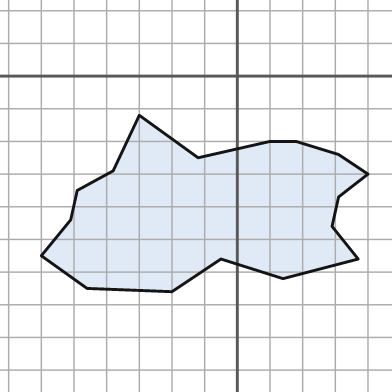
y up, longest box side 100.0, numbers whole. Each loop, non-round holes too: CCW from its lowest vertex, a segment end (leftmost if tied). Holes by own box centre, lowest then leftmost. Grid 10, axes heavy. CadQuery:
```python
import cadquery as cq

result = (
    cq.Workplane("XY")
    .moveTo(-20.0, -66.0)
    .lineTo(-5.0, -56.0)
    .lineTo(14.0, -62.0)
    .lineTo(37.0, -56.0)
    .lineTo(29.0, -46.0)
    .lineTo(31.0, -37.0)
    .lineTo(40.0, -30.0)
    .lineTo(31.0, -24.0)
    .lineTo(18.0, -20.0)
    .lineTo(10.0, -20.0)
    .lineTo(-12.0, -25.0)
    .lineTo(-30.0, -12.0)
    .lineTo(-38.0, -29.0)
    .lineTo(-49.0, -35.0)
    .lineTo(-51.0, -44.0)
    .lineTo(-60.0, -55.0)
    .lineTo(-46.0, -65.0)
    .close()
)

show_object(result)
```